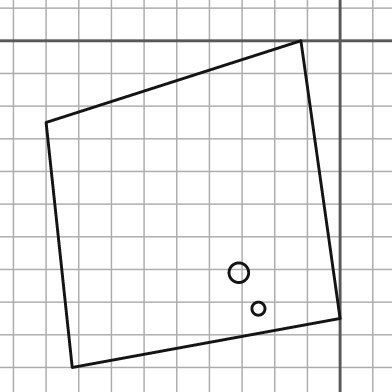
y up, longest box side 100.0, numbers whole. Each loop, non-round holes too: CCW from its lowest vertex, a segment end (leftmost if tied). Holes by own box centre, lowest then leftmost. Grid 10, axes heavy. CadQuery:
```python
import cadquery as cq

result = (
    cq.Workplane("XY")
    .moveTo(-82.0, -100.0)
    .lineTo(0.0, -85.0)
    .lineTo(-12.0, 0.0)
    .lineTo(-90.0, -25.0)
    .close()
    .moveTo(-25.0, -82.0)
    .circle(2.0)
    .moveTo(-31.0, -71.0)
    .circle(3.0)
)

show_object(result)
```